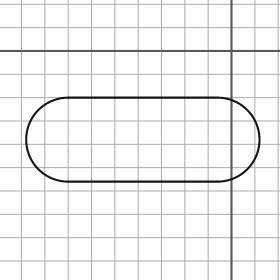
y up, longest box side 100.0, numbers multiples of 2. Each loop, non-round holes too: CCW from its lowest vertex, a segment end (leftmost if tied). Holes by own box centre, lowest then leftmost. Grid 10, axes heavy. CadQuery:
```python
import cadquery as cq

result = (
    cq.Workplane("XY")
    .moveTo(-70.0, -56.0)
    .lineTo(-6.0, -56.0)
    .threePointArc((12.0, -38.0), (-6.0, -20.0))
    .lineTo(-70.0, -20.0)
    .threePointArc((-88.0, -38.0), (-70.0, -56.0))
    .close()
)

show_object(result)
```